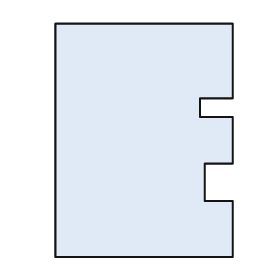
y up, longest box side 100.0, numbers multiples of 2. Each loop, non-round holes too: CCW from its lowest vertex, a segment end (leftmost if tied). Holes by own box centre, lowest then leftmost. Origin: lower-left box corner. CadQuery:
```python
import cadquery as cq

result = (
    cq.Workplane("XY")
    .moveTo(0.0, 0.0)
    .lineTo(76.0, 0.0)
    .lineTo(76.0, 24.0)
    .lineTo(64.0, 24.0)
    .lineTo(64.0, 40.0)
    .lineTo(76.0, 40.0)
    .lineTo(76.0, 60.0)
    .lineTo(62.0, 60.0)
    .lineTo(62.0, 68.0)
    .lineTo(76.0, 68.0)
    .lineTo(76.0, 100.0)
    .lineTo(0.0, 100.0)
    .close()
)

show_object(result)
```